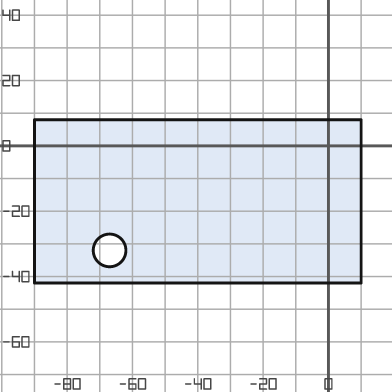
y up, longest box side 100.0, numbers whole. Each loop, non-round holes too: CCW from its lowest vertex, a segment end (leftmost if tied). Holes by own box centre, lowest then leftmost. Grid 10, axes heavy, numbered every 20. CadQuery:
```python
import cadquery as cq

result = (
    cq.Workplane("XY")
    .moveTo(-90.0, -42.0)
    .lineTo(10.0, -42.0)
    .lineTo(10.0, 8.0)
    .lineTo(-90.0, 8.0)
    .close()
    .moveTo(-67.0, -32.0)
    .circle(5.0)
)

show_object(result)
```